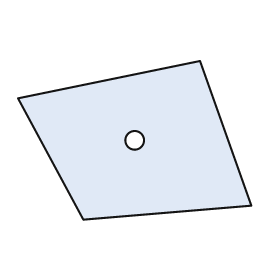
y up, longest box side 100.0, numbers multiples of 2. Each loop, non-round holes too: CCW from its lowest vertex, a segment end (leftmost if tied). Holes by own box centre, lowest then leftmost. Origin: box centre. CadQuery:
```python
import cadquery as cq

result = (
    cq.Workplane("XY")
    .moveTo(-22.0, -34.0)
    .lineTo(50.0, -28.0)
    .lineTo(28.0, 34.0)
    .lineTo(-50.0, 18.0)
    .close()
    .moveTo(0.0, 0.0)
    .circle(4.0)
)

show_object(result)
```